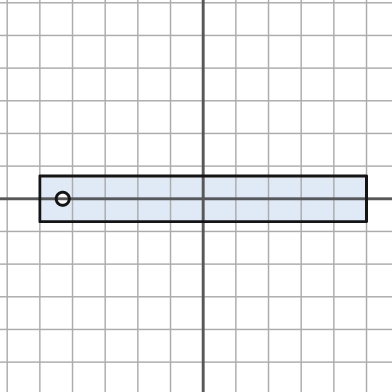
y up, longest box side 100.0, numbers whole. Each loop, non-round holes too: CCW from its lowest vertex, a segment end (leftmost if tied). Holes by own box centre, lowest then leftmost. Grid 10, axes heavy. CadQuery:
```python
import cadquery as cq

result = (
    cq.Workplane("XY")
    .moveTo(-50.0, -7.0)
    .lineTo(50.0, -7.0)
    .lineTo(50.0, 7.0)
    .lineTo(-50.0, 7.0)
    .close()
    .moveTo(-43.0, 0.0)
    .circle(2.0)
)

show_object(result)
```